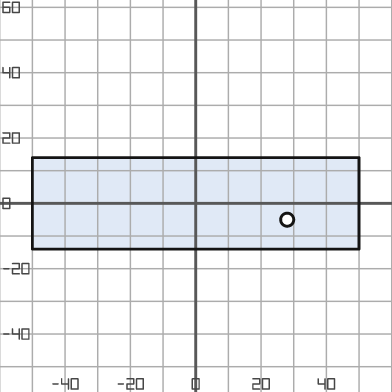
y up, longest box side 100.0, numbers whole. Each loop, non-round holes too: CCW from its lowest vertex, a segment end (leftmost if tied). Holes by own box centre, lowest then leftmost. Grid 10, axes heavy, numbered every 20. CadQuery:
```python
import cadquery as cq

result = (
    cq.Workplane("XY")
    .moveTo(-50.0, -14.0)
    .lineTo(50.0, -14.0)
    .lineTo(50.0, 14.0)
    .lineTo(-50.0, 14.0)
    .close()
    .moveTo(28.0, -5.0)
    .circle(2.0)
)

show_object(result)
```